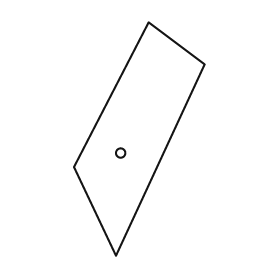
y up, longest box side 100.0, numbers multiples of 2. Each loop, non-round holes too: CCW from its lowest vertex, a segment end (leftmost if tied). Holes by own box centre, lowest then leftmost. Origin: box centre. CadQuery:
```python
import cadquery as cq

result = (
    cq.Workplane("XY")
    .moveTo(-10.0, -50.0)
    .lineTo(28.0, 32.0)
    .lineTo(4.0, 50.0)
    .lineTo(-28.0, -12.0)
    .close()
    .moveTo(-8.0, -6.0)
    .circle(2.0)
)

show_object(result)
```